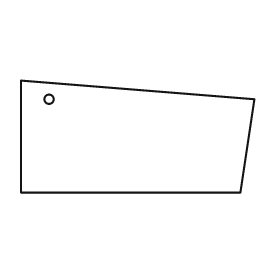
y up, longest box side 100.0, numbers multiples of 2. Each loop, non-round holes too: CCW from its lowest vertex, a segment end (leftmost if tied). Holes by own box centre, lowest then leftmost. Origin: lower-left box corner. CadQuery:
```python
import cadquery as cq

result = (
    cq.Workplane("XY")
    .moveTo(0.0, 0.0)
    .lineTo(94.0, 0.0)
    .lineTo(100.0, 40.0)
    .lineTo(0.0, 48.0)
    .close()
    .moveTo(12.0, 40.0)
    .circle(2.0)
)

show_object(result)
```